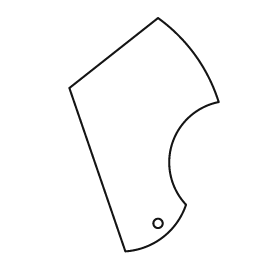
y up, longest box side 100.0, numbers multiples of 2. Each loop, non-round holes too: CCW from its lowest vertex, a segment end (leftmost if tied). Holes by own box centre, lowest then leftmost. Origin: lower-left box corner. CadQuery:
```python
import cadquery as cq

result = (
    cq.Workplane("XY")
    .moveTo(24.0, 0.0)
    .threePointArc((40.0, 6.0), (50.0, 20.0))
    .threePointArc((44.0, 46.0), (64.0, 64.0))
    .threePointArc((54.0, 84.0), (38.0, 100.0))
    .lineTo(0.0, 70.0)
    .close()
    .moveTo(38.0, 12.0)
    .circle(2.0)
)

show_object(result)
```